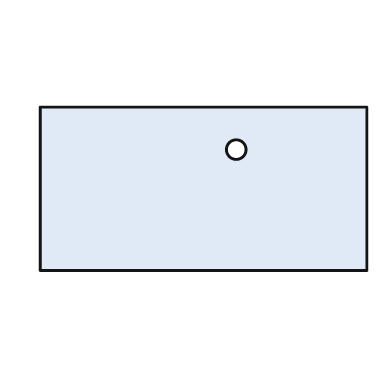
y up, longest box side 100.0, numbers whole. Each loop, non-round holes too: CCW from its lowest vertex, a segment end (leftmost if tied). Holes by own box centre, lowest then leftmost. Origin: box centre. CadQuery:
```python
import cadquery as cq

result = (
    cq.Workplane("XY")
    .moveTo(-50.0, -25.0)
    .lineTo(50.0, -25.0)
    .lineTo(50.0, 25.0)
    .lineTo(-50.0, 25.0)
    .close()
    .moveTo(10.0, 12.0)
    .circle(3.0)
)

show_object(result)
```